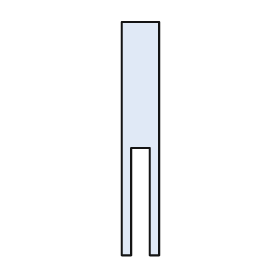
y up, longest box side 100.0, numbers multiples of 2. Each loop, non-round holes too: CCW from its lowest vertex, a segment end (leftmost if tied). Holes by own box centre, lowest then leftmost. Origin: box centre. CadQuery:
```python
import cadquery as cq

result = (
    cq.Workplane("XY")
    .moveTo(-8.0, -50.0)
    .lineTo(-4.0, -50.0)
    .lineTo(-4.0, -4.0)
    .lineTo(4.0, -4.0)
    .lineTo(4.0, -50.0)
    .lineTo(8.0, -50.0)
    .lineTo(8.0, 50.0)
    .lineTo(-8.0, 50.0)
    .close()
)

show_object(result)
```